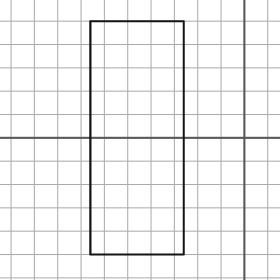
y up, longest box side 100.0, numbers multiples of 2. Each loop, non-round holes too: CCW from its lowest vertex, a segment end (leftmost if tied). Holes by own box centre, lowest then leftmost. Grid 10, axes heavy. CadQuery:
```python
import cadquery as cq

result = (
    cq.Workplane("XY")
    .moveTo(-66.0, -50.0)
    .lineTo(-26.0, -50.0)
    .lineTo(-26.0, 50.0)
    .lineTo(-66.0, 50.0)
    .close()
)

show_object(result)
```